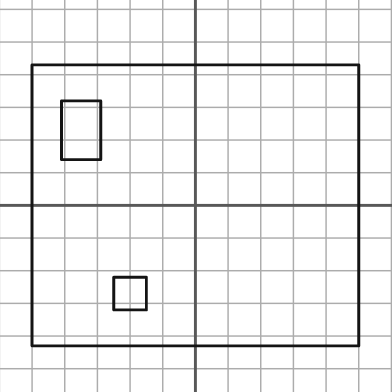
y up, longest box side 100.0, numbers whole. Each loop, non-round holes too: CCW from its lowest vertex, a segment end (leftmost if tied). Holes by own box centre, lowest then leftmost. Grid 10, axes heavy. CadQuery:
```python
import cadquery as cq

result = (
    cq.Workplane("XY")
    .moveTo(-50.0, -43.0)
    .lineTo(50.0, -43.0)
    .lineTo(50.0, 43.0)
    .lineTo(-50.0, 43.0)
    .close()
    .moveTo(-25.0, -32.0)
    .lineTo(-15.0, -32.0)
    .lineTo(-15.0, -22.0)
    .lineTo(-25.0, -22.0)
    .close()
    .moveTo(-41.0, 14.0)
    .lineTo(-29.0, 14.0)
    .lineTo(-29.0, 32.0)
    .lineTo(-41.0, 32.0)
    .close()
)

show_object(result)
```